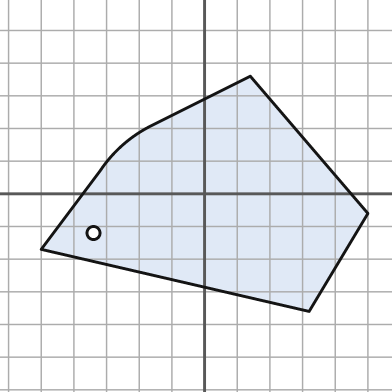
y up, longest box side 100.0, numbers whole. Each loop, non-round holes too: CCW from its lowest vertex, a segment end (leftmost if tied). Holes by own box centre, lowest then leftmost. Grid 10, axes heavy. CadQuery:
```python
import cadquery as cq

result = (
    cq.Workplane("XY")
    .moveTo(32.0, -36.0)
    .lineTo(50.0, -6.0)
    .lineTo(14.0, 36.0)
    .lineTo(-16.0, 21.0)
    .threePointArc((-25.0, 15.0), (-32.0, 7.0))
    .lineTo(-50.0, -17.0)
    .close()
    .moveTo(-34.0, -12.0)
    .circle(2.0)
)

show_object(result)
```